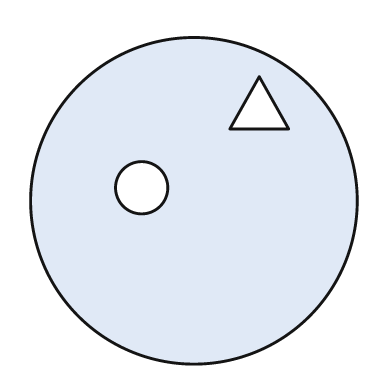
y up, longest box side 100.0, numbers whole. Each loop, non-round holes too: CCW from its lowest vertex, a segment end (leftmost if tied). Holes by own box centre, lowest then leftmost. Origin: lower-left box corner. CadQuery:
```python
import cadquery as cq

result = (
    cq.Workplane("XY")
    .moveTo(50.0, 50.0)
    .circle(50.0)
    .moveTo(34.0, 54.0)
    .circle(8.0)
    .moveTo(61.0, 72.0)
    .lineTo(79.0, 72.0)
    .lineTo(70.0, 88.0)
    .close()
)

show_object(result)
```